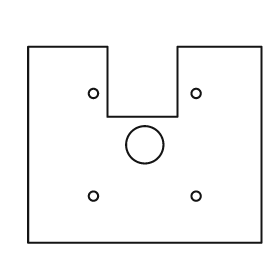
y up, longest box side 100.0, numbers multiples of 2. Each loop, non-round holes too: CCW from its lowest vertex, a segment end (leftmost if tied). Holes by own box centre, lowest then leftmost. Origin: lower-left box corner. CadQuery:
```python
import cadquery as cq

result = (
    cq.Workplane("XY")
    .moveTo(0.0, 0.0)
    .lineTo(100.0, 0.0)
    .lineTo(100.0, 84.0)
    .lineTo(64.0, 84.0)
    .lineTo(64.0, 54.0)
    .lineTo(34.0, 54.0)
    .lineTo(34.0, 84.0)
    .lineTo(0.0, 84.0)
    .close()
    .moveTo(28.0, 20.0)
    .circle(2.0)
    .moveTo(72.0, 20.0)
    .circle(2.0)
    .moveTo(50.0, 42.0)
    .circle(8.0)
    .moveTo(28.0, 64.0)
    .circle(2.0)
    .moveTo(72.0, 64.0)
    .circle(2.0)
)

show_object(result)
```